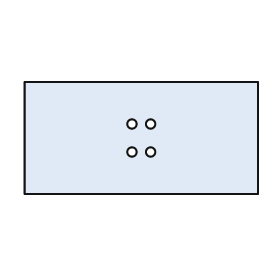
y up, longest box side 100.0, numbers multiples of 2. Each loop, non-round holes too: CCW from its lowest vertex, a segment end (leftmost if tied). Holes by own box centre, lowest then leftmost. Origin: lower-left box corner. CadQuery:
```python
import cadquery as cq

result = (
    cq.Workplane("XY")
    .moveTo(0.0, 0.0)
    .lineTo(100.0, 0.0)
    .lineTo(100.0, 48.0)
    .lineTo(0.0, 48.0)
    .close()
    .moveTo(46.0, 18.0)
    .circle(2.0)
    .moveTo(54.0, 18.0)
    .circle(2.0)
    .moveTo(46.0, 30.0)
    .circle(2.0)
    .moveTo(54.0, 30.0)
    .circle(2.0)
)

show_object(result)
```